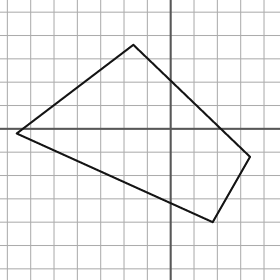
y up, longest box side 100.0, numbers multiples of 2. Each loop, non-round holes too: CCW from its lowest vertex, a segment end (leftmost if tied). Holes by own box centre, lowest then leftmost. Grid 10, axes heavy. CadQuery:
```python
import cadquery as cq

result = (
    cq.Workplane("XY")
    .moveTo(18.0, -40.0)
    .lineTo(34.0, -12.0)
    .lineTo(-16.0, 36.0)
    .lineTo(-66.0, -2.0)
    .close()
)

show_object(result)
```